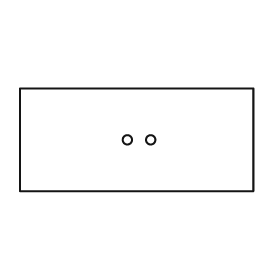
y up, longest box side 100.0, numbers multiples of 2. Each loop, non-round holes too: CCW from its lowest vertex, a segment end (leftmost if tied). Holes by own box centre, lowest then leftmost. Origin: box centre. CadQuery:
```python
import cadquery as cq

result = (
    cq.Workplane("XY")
    .moveTo(-50.0, -22.0)
    .lineTo(50.0, -22.0)
    .lineTo(50.0, 22.0)
    .lineTo(-50.0, 22.0)
    .close()
    .moveTo(-4.0, 0.0)
    .circle(2.0)
    .moveTo(6.0, 0.0)
    .circle(2.0)
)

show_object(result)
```